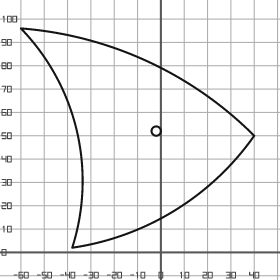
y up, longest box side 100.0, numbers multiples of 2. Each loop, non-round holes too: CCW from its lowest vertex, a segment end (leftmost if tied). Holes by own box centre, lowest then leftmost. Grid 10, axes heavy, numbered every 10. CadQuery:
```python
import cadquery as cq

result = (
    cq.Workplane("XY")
    .moveTo(-38.0, 2.0)
    .threePointArc((6.0, 18.0), (40.0, 50.0))
    .threePointArc((-6.0, 82.0), (-60.0, 96.0))
    .threePointArc((-36.0, 52.0), (-38.0, 2.0))
    .close()
    .moveTo(-2.0, 52.0)
    .circle(2.0)
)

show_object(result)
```